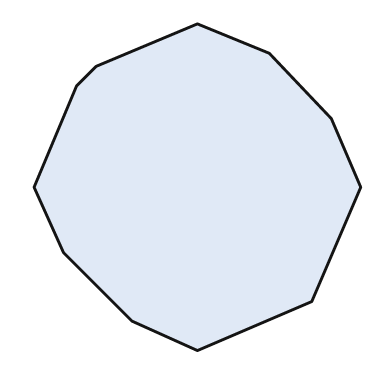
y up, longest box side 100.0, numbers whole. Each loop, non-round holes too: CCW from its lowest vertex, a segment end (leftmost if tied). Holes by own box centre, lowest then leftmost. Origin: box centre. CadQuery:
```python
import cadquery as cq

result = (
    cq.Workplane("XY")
    .moveTo(0.0, -50.0)
    .lineTo(35.0, -35.0)
    .lineTo(50.0, 0.0)
    .lineTo(41.0, 21.0)
    .lineTo(22.0, 41.0)
    .lineTo(0.0, 50.0)
    .lineTo(-31.0, 37.0)
    .lineTo(-37.0, 31.0)
    .lineTo(-50.0, 0.0)
    .lineTo(-41.0, -20.0)
    .lineTo(-20.0, -41.0)
    .close()
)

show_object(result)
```